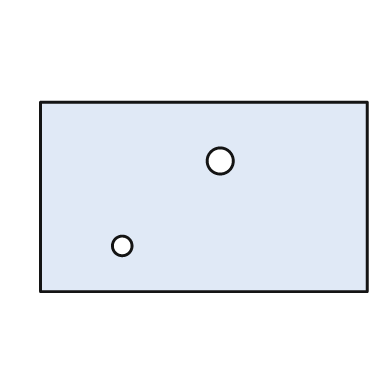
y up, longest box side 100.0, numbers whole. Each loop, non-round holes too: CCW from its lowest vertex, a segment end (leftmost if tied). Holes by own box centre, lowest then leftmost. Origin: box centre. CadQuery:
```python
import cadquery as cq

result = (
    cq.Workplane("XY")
    .moveTo(-50.0, -29.0)
    .lineTo(50.0, -29.0)
    .lineTo(50.0, 29.0)
    .lineTo(-50.0, 29.0)
    .close()
    .moveTo(-25.0, -15.0)
    .circle(3.0)
    .moveTo(5.0, 11.0)
    .circle(4.0)
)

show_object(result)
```